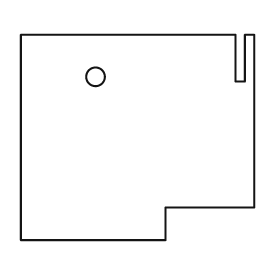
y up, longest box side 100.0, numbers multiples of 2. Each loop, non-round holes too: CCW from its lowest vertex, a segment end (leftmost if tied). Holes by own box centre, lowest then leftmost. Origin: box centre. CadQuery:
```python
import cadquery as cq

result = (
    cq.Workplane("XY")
    .moveTo(-50.0, -44.0)
    .lineTo(12.0, -44.0)
    .lineTo(12.0, -30.0)
    .lineTo(50.0, -30.0)
    .lineTo(50.0, 44.0)
    .lineTo(46.0, 44.0)
    .lineTo(46.0, 24.0)
    .lineTo(42.0, 24.0)
    .lineTo(42.0, 44.0)
    .lineTo(-50.0, 44.0)
    .close()
    .moveTo(-18.0, 26.0)
    .circle(4.0)
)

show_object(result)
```